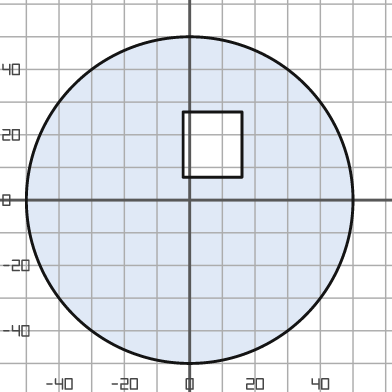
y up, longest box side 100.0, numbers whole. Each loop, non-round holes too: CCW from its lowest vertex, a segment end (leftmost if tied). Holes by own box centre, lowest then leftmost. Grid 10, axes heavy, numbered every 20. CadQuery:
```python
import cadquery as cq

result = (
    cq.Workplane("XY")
    .moveTo(0.0, 0.0)
    .circle(50.0)
    .moveTo(-2.0, 7.0)
    .lineTo(16.0, 7.0)
    .lineTo(16.0, 27.0)
    .lineTo(-2.0, 27.0)
    .close()
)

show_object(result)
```